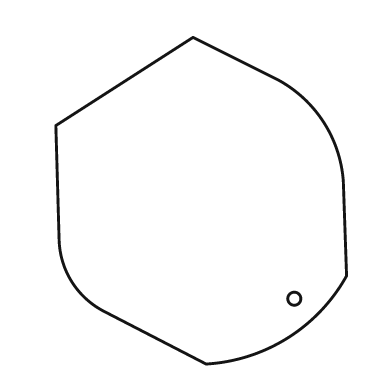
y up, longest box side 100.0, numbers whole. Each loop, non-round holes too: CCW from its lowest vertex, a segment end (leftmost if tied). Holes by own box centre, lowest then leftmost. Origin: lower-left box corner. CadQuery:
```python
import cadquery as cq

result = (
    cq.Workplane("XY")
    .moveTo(46.0, 0.0)
    .threePointArc((71.0, 8.0), (89.0, 27.0))
    .lineTo(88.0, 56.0)
    .threePointArc((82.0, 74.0), (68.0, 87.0))
    .lineTo(42.0, 100.0)
    .lineTo(0.0, 73.0)
    .lineTo(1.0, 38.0)
    .threePointArc((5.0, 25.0), (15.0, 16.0))
    .close()
    .moveTo(73.0, 20.0)
    .circle(2.0)
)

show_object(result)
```